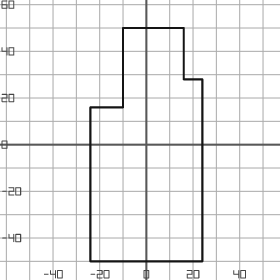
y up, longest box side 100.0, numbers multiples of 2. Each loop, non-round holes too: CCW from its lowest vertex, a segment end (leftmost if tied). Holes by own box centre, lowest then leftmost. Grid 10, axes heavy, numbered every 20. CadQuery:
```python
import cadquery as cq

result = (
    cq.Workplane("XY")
    .moveTo(-24.0, -50.0)
    .lineTo(24.0, -50.0)
    .lineTo(24.0, 28.0)
    .lineTo(16.0, 28.0)
    .lineTo(16.0, 50.0)
    .lineTo(-10.0, 50.0)
    .lineTo(-10.0, 16.0)
    .lineTo(-24.0, 16.0)
    .close()
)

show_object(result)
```